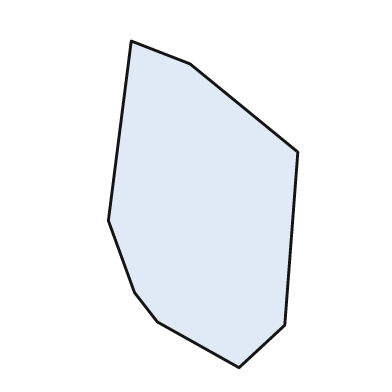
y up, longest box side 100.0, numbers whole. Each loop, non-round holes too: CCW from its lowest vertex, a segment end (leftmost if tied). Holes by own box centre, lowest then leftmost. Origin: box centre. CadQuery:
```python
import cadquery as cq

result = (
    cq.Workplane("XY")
    .moveTo(11.0, -50.0)
    .lineTo(25.0, -37.0)
    .lineTo(29.0, 16.0)
    .lineTo(-4.0, 43.0)
    .lineTo(-22.0, 50.0)
    .lineTo(-29.0, -5.0)
    .lineTo(-21.0, -27.0)
    .lineTo(-14.0, -36.0)
    .close()
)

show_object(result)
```